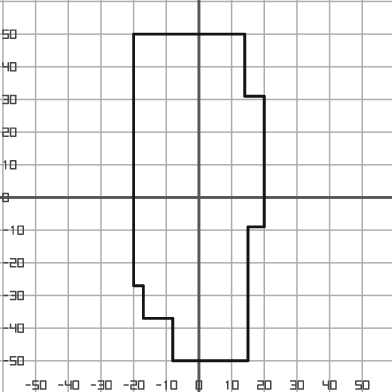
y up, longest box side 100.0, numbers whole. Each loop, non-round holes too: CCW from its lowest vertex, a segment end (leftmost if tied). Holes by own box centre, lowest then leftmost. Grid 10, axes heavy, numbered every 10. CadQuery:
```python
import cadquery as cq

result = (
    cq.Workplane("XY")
    .moveTo(-8.0, -50.0)
    .lineTo(15.0, -50.0)
    .lineTo(15.0, -9.0)
    .lineTo(20.0, -9.0)
    .lineTo(20.0, 31.0)
    .lineTo(14.0, 31.0)
    .lineTo(14.0, 50.0)
    .lineTo(-20.0, 50.0)
    .lineTo(-20.0, -27.0)
    .lineTo(-17.0, -27.0)
    .lineTo(-17.0, -37.0)
    .lineTo(-8.0, -37.0)
    .close()
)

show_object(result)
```